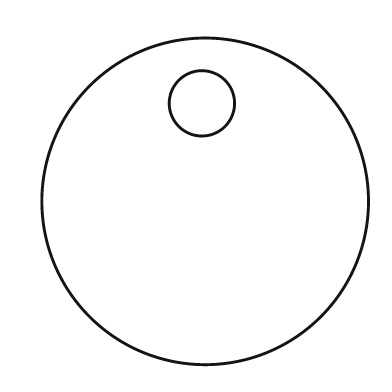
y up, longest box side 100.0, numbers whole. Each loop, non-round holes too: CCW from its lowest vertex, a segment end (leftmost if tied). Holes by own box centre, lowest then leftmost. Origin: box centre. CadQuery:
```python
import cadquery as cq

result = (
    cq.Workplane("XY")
    .moveTo(0.0, 0.0)
    .circle(50.0)
    .moveTo(-1.0, 30.0)
    .circle(10.0)
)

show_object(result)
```